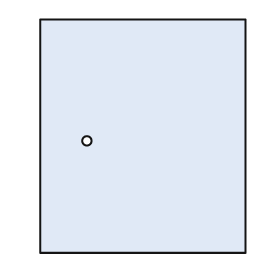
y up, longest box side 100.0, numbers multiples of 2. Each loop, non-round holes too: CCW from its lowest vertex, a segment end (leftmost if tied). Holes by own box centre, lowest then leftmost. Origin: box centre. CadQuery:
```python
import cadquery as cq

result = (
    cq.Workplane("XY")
    .moveTo(-44.0, -50.0)
    .lineTo(44.0, -50.0)
    .lineTo(44.0, 50.0)
    .lineTo(-44.0, 50.0)
    .close()
    .moveTo(-24.0, -2.0)
    .circle(2.0)
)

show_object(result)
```